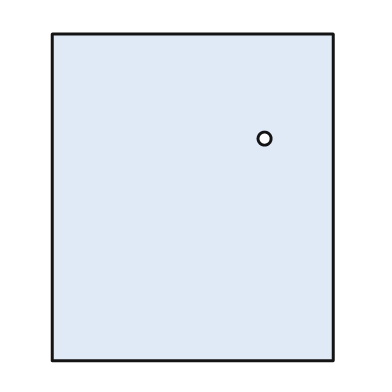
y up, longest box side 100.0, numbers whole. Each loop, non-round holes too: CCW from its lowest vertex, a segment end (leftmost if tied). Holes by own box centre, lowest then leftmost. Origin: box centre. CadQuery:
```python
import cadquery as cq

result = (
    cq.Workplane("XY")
    .moveTo(-43.0, -50.0)
    .lineTo(43.0, -50.0)
    .lineTo(43.0, 50.0)
    .lineTo(-43.0, 50.0)
    .close()
    .moveTo(22.0, 18.0)
    .circle(2.0)
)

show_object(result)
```